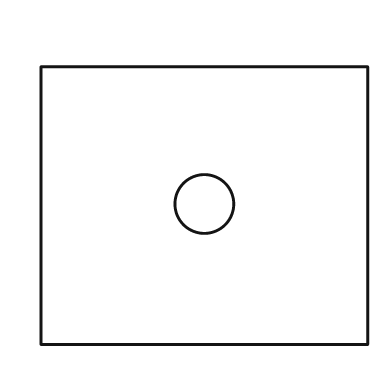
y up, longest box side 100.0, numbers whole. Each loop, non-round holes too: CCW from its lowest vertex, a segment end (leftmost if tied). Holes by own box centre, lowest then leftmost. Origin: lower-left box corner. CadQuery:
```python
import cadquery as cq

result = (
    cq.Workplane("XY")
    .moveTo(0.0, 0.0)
    .lineTo(100.0, 0.0)
    .lineTo(100.0, 85.0)
    .lineTo(0.0, 85.0)
    .close()
    .moveTo(50.0, 43.0)
    .circle(9.0)
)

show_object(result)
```